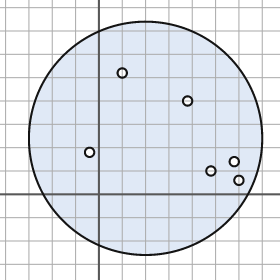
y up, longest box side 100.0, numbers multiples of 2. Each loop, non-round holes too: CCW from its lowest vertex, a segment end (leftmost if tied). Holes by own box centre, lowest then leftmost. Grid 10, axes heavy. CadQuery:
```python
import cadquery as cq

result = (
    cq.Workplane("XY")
    .moveTo(20.0, 24.0)
    .circle(50.0)
    .moveTo(60.0, 6.0)
    .circle(2.0)
    .moveTo(48.0, 10.0)
    .circle(2.0)
    .moveTo(58.0, 14.0)
    .circle(2.0)
    .moveTo(-4.0, 18.0)
    .circle(2.0)
    .moveTo(38.0, 40.0)
    .circle(2.0)
    .moveTo(10.0, 52.0)
    .circle(2.0)
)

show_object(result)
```